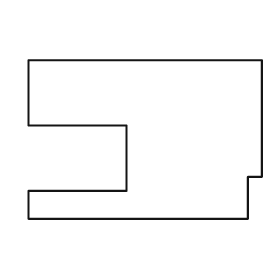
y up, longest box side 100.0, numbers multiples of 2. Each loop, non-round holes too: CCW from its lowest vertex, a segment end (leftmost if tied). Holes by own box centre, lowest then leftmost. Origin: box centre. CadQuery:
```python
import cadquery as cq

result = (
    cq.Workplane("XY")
    .moveTo(-50.0, -34.0)
    .lineTo(44.0, -34.0)
    .lineTo(44.0, -16.0)
    .lineTo(50.0, -16.0)
    .lineTo(50.0, 34.0)
    .lineTo(-50.0, 34.0)
    .lineTo(-50.0, 6.0)
    .lineTo(-8.0, 6.0)
    .lineTo(-8.0, -22.0)
    .lineTo(-50.0, -22.0)
    .close()
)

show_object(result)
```